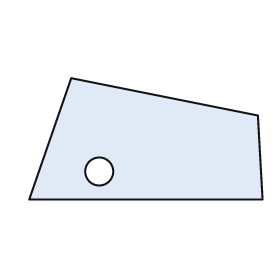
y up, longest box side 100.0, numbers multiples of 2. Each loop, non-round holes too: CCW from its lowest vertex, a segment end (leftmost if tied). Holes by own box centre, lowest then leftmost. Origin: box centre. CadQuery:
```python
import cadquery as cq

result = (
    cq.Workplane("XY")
    .moveTo(-50.0, -26.0)
    .lineTo(50.0, -26.0)
    .lineTo(48.0, 10.0)
    .lineTo(-32.0, 26.0)
    .close()
    .moveTo(-20.0, -14.0)
    .circle(6.0)
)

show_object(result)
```